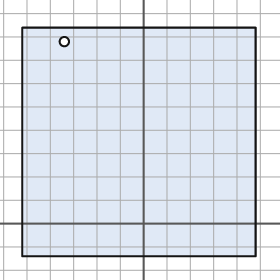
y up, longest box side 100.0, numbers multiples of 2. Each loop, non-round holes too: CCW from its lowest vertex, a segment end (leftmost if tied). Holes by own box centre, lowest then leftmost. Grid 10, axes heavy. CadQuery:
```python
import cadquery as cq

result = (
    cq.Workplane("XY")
    .moveTo(-52.0, -14.0)
    .lineTo(48.0, -14.0)
    .lineTo(48.0, 84.0)
    .lineTo(-52.0, 84.0)
    .close()
    .moveTo(-34.0, 78.0)
    .circle(2.0)
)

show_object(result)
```